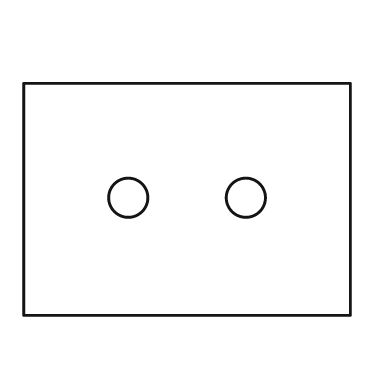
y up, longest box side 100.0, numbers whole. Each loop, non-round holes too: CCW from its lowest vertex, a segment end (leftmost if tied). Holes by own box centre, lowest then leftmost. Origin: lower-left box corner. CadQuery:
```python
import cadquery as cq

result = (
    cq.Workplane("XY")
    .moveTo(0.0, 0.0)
    .lineTo(100.0, 0.0)
    .lineTo(100.0, 71.0)
    .lineTo(0.0, 71.0)
    .close()
    .moveTo(32.0, 36.0)
    .circle(6.0)
    .moveTo(68.0, 36.0)
    .circle(6.0)
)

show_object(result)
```